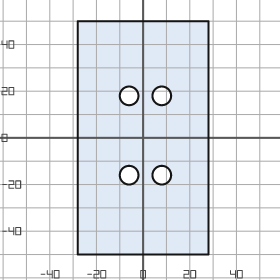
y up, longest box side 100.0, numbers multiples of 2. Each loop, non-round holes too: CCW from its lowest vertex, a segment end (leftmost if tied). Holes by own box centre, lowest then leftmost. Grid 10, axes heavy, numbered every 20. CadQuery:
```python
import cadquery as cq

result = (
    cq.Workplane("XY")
    .moveTo(-28.0, -50.0)
    .lineTo(28.0, -50.0)
    .lineTo(28.0, 50.0)
    .lineTo(-28.0, 50.0)
    .close()
    .moveTo(-6.0, -16.0)
    .circle(4.0)
    .moveTo(8.0, -16.0)
    .circle(4.0)
    .moveTo(-6.0, 18.0)
    .circle(4.0)
    .moveTo(8.0, 18.0)
    .circle(4.0)
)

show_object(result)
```